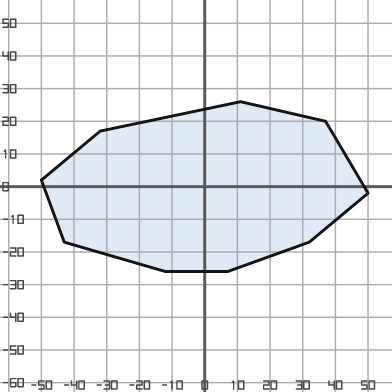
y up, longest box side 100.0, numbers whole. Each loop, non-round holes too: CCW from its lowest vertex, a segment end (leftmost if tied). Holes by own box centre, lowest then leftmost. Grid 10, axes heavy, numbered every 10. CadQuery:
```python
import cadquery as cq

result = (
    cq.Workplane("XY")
    .moveTo(-12.0, -26.0)
    .lineTo(7.0, -26.0)
    .lineTo(32.0, -17.0)
    .lineTo(50.0, -2.0)
    .lineTo(37.0, 20.0)
    .lineTo(11.0, 26.0)
    .lineTo(-32.0, 17.0)
    .lineTo(-50.0, 2.0)
    .lineTo(-43.0, -17.0)
    .close()
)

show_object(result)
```